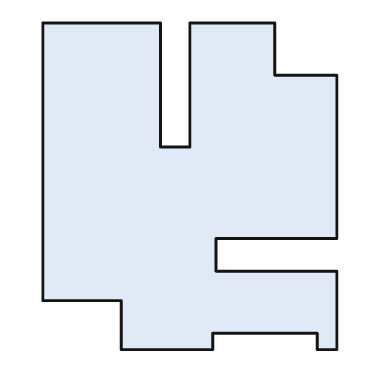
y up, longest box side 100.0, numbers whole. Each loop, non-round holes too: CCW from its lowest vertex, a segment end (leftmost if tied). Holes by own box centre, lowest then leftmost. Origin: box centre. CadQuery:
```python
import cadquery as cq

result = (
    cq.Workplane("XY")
    .moveTo(-21.0, -50.0)
    .lineTo(7.0, -50.0)
    .lineTo(7.0, -45.0)
    .lineTo(39.0, -45.0)
    .lineTo(39.0, -50.0)
    .lineTo(45.0, -50.0)
    .lineTo(45.0, -26.0)
    .lineTo(8.0, -26.0)
    .lineTo(8.0, -16.0)
    .lineTo(45.0, -16.0)
    .lineTo(45.0, 34.0)
    .lineTo(26.0, 34.0)
    .lineTo(26.0, 50.0)
    .lineTo(0.0, 50.0)
    .lineTo(0.0, 12.0)
    .lineTo(-9.0, 12.0)
    .lineTo(-9.0, 50.0)
    .lineTo(-45.0, 50.0)
    .lineTo(-45.0, -35.0)
    .lineTo(-21.0, -35.0)
    .close()
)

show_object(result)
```